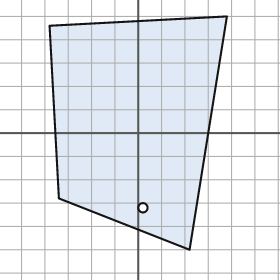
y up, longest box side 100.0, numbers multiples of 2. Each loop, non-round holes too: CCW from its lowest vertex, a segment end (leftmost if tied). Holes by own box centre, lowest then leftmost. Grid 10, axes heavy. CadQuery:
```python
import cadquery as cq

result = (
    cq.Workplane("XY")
    .moveTo(22.0, -50.0)
    .lineTo(38.0, 50.0)
    .lineTo(-38.0, 46.0)
    .lineTo(-34.0, -28.0)
    .close()
    .moveTo(2.0, -32.0)
    .circle(2.0)
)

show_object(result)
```